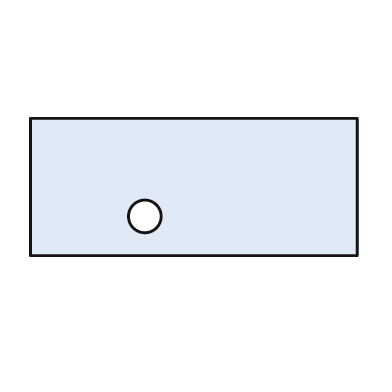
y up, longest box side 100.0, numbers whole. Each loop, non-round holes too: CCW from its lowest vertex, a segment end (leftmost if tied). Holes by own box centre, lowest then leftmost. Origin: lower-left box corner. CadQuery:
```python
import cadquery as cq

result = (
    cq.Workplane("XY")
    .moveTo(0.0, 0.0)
    .lineTo(100.0, 0.0)
    .lineTo(100.0, 42.0)
    .lineTo(0.0, 42.0)
    .close()
    .moveTo(35.0, 12.0)
    .circle(5.0)
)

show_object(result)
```